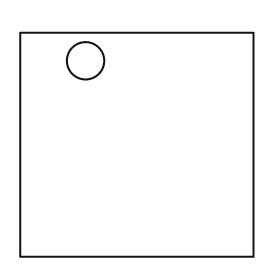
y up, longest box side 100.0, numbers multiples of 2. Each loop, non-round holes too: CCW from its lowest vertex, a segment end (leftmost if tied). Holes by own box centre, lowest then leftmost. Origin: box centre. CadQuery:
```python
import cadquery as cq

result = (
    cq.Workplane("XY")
    .moveTo(-50.0, -48.0)
    .lineTo(50.0, -48.0)
    .lineTo(50.0, 48.0)
    .lineTo(-50.0, 48.0)
    .close()
    .moveTo(-22.0, 36.0)
    .circle(8.0)
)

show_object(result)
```